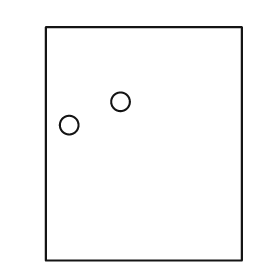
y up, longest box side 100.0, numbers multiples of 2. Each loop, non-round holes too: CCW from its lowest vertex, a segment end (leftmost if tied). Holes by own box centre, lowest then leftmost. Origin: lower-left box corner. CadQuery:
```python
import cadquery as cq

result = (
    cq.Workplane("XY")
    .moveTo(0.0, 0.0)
    .lineTo(84.0, 0.0)
    .lineTo(84.0, 100.0)
    .lineTo(0.0, 100.0)
    .close()
    .moveTo(10.0, 58.0)
    .circle(4.0)
    .moveTo(32.0, 68.0)
    .circle(4.0)
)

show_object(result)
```